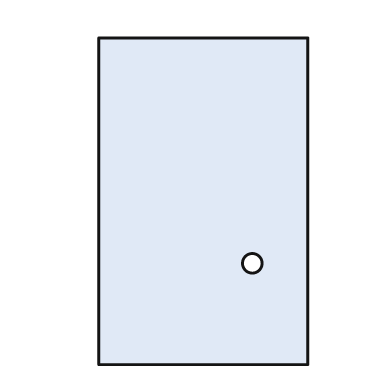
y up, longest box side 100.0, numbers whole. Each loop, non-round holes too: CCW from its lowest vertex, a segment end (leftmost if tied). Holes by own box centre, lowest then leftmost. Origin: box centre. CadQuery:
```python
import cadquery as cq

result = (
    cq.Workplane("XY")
    .moveTo(-32.0, -50.0)
    .lineTo(32.0, -50.0)
    .lineTo(32.0, 50.0)
    .lineTo(-32.0, 50.0)
    .close()
    .moveTo(15.0, -19.0)
    .circle(3.0)
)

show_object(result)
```